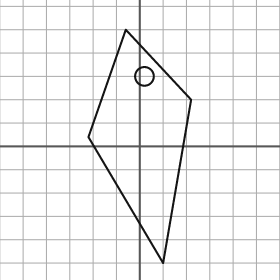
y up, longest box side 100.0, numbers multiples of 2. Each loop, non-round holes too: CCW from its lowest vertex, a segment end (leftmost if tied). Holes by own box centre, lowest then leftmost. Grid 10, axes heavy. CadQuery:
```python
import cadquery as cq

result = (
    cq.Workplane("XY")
    .moveTo(10.0, -50.0)
    .lineTo(22.0, 20.0)
    .lineTo(-6.0, 50.0)
    .lineTo(-22.0, 4.0)
    .close()
    .moveTo(2.0, 30.0)
    .circle(4.0)
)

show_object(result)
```